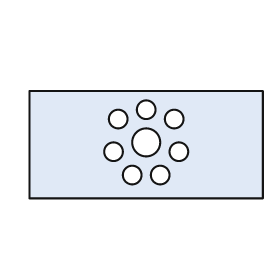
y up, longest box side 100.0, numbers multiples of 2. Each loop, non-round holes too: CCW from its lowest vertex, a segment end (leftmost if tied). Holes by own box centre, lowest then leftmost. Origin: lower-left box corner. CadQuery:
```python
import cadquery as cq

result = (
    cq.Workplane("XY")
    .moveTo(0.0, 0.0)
    .lineTo(100.0, 0.0)
    .lineTo(100.0, 46.0)
    .lineTo(0.0, 46.0)
    .close()
    .moveTo(44.0, 10.0)
    .circle(4.0)
    .moveTo(56.0, 10.0)
    .circle(4.0)
    .moveTo(36.0, 20.0)
    .circle(4.0)
    .moveTo(64.0, 20.0)
    .circle(4.0)
    .moveTo(50.0, 24.0)
    .circle(6.0)
    .moveTo(38.0, 34.0)
    .circle(4.0)
    .moveTo(62.0, 34.0)
    .circle(4.0)
    .moveTo(50.0, 38.0)
    .circle(4.0)
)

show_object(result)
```